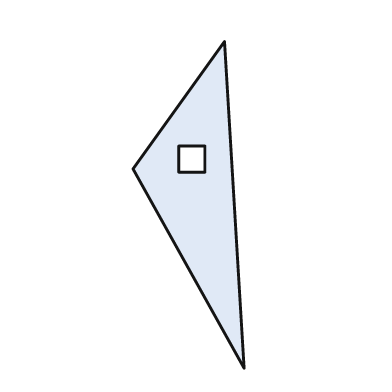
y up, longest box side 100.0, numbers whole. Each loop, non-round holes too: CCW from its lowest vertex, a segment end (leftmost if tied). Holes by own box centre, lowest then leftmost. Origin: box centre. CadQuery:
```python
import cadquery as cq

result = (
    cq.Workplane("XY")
    .moveTo(17.0, -50.0)
    .lineTo(11.0, 50.0)
    .lineTo(-17.0, 11.0)
    .close()
    .moveTo(-3.0, 10.0)
    .lineTo(5.0, 10.0)
    .lineTo(5.0, 18.0)
    .lineTo(-3.0, 18.0)
    .close()
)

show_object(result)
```